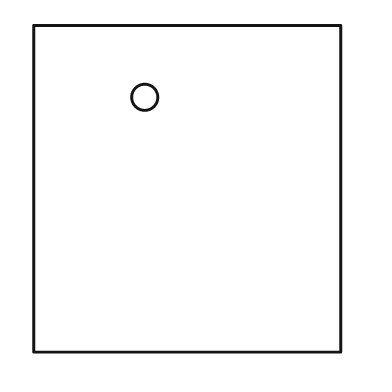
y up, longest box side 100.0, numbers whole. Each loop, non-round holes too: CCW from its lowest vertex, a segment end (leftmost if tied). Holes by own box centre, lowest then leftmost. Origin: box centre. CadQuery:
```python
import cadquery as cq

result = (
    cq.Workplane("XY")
    .moveTo(-47.0, -50.0)
    .lineTo(47.0, -50.0)
    .lineTo(47.0, 50.0)
    .lineTo(-47.0, 50.0)
    .close()
    .moveTo(-13.0, 28.0)
    .circle(4.0)
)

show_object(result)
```